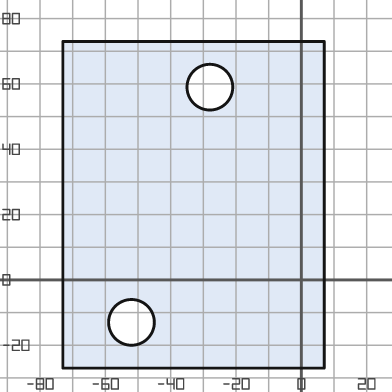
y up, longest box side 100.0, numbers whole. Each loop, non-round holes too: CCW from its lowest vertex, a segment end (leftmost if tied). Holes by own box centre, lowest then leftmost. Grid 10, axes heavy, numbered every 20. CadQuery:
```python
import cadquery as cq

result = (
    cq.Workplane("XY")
    .moveTo(-73.0, -27.0)
    .lineTo(7.0, -27.0)
    .lineTo(7.0, 73.0)
    .lineTo(-73.0, 73.0)
    .close()
    .moveTo(-52.0, -13.0)
    .circle(7.0)
    .moveTo(-28.0, 59.0)
    .circle(7.0)
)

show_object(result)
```